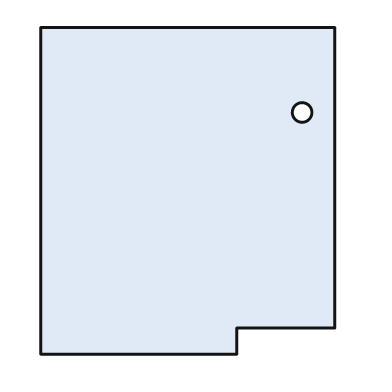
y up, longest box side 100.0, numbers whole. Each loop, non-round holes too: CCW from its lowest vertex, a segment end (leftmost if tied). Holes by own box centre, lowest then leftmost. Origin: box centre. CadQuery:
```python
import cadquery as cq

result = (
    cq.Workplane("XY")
    .moveTo(-45.0, -50.0)
    .lineTo(15.0, -50.0)
    .lineTo(15.0, -42.0)
    .lineTo(45.0, -42.0)
    .lineTo(45.0, 50.0)
    .lineTo(-45.0, 50.0)
    .close()
    .moveTo(35.0, 24.0)
    .circle(3.0)
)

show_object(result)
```